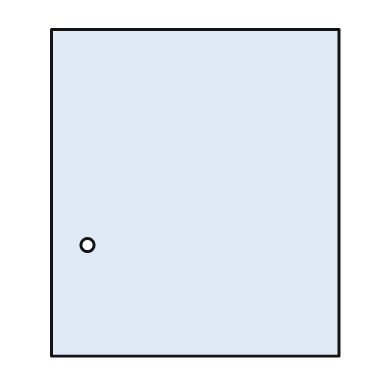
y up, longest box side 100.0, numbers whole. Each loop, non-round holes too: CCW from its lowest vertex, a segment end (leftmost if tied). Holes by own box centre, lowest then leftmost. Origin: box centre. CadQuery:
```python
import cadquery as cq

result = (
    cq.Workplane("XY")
    .moveTo(-44.0, -50.0)
    .lineTo(44.0, -50.0)
    .lineTo(44.0, 50.0)
    .lineTo(-44.0, 50.0)
    .close()
    .moveTo(-33.0, -16.0)
    .circle(2.0)
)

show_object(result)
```